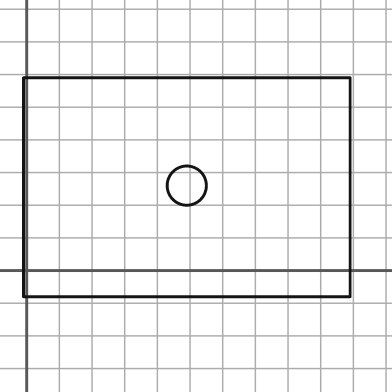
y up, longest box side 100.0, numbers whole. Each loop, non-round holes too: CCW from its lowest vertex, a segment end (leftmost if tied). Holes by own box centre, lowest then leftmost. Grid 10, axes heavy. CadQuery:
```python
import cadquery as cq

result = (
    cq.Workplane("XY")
    .moveTo(-1.0, -8.0)
    .lineTo(99.0, -8.0)
    .lineTo(99.0, 59.0)
    .lineTo(-1.0, 59.0)
    .close()
    .moveTo(49.0, 26.0)
    .circle(6.0)
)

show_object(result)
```